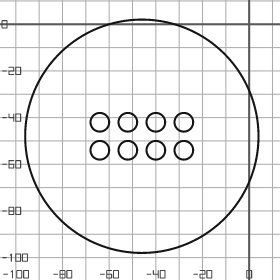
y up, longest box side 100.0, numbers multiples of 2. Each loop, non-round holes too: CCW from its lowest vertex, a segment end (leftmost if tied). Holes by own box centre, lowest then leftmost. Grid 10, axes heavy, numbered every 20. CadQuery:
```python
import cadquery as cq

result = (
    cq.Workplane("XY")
    .moveTo(-46.0, -48.0)
    .circle(50.0)
    .moveTo(-64.0, -54.0)
    .circle(4.0)
    .moveTo(-52.0, -54.0)
    .circle(4.0)
    .moveTo(-40.0, -54.0)
    .circle(4.0)
    .moveTo(-28.0, -54.0)
    .circle(4.0)
    .moveTo(-64.0, -42.0)
    .circle(4.0)
    .moveTo(-52.0, -42.0)
    .circle(4.0)
    .moveTo(-40.0, -42.0)
    .circle(4.0)
    .moveTo(-28.0, -42.0)
    .circle(4.0)
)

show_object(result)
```